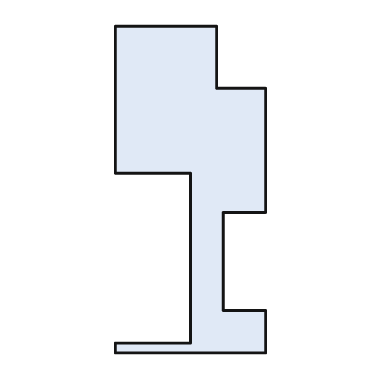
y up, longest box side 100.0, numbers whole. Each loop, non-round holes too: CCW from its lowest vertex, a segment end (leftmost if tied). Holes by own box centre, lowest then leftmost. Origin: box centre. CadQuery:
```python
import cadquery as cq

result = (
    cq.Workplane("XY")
    .moveTo(-23.0, -50.0)
    .lineTo(23.0, -50.0)
    .lineTo(23.0, -37.0)
    .lineTo(10.0, -37.0)
    .lineTo(10.0, -7.0)
    .lineTo(23.0, -7.0)
    .lineTo(23.0, 31.0)
    .lineTo(8.0, 31.0)
    .lineTo(8.0, 50.0)
    .lineTo(-23.0, 50.0)
    .lineTo(-23.0, 5.0)
    .lineTo(0.0, 5.0)
    .lineTo(0.0, -47.0)
    .lineTo(-23.0, -47.0)
    .close()
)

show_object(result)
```